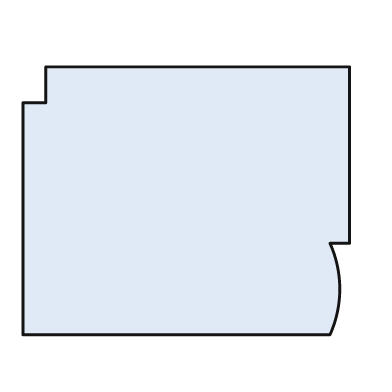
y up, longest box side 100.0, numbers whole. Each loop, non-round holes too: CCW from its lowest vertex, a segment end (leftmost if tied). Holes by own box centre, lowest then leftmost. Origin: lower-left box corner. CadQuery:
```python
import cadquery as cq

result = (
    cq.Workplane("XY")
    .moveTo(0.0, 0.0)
    .lineTo(94.0, 0.0)
    .threePointArc((97.0, 14.0), (94.0, 28.0))
    .lineTo(100.0, 28.0)
    .lineTo(100.0, 82.0)
    .lineTo(7.0, 82.0)
    .lineTo(7.0, 71.0)
    .lineTo(0.0, 71.0)
    .close()
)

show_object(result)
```